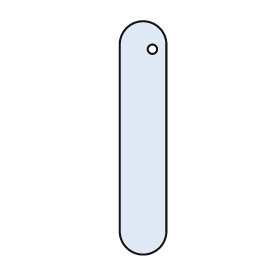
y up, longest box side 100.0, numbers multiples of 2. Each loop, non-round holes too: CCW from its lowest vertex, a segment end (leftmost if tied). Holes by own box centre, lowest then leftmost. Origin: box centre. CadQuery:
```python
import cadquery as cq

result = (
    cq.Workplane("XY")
    .moveTo(-10.0, -40.0)
    .threePointArc((0.0, -50.0), (10.0, -40.0))
    .lineTo(10.0, 40.0)
    .threePointArc((0.0, 50.0), (-10.0, 40.0))
    .close()
    .moveTo(4.0, 38.0)
    .circle(2.0)
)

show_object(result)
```